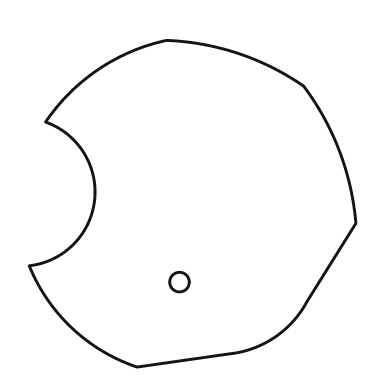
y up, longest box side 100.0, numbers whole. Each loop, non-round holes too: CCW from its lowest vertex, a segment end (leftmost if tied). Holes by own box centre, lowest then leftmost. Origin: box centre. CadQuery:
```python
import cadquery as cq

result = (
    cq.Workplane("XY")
    .moveTo(-17.0, -50.0)
    .lineTo(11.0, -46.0)
    .threePointArc((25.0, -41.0), (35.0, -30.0))
    .lineTo(50.0, -6.0)
    .threePointArc((45.0, 16.0), (34.0, 36.0))
    .threePointArc((14.0, 46.0), (-8.0, 50.0))
    .threePointArc((-29.0, 41.0), (-45.0, 25.0))
    .threePointArc((-30.0, 1.0), (-50.0, -19.0))
    .threePointArc((-37.0, -38.0), (-17.0, -50.0))
    .close()
    .moveTo(-4.0, -24.0)
    .circle(3.0)
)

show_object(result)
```